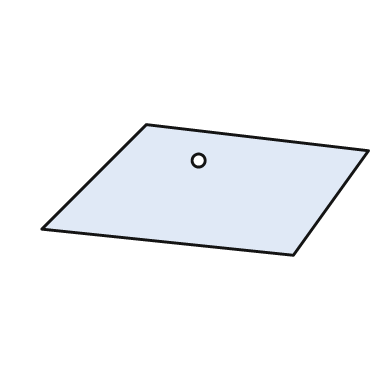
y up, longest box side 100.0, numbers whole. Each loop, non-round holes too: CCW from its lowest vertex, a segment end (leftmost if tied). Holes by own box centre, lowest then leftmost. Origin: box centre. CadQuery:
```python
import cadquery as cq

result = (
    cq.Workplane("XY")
    .moveTo(27.0, -20.0)
    .lineTo(50.0, 12.0)
    .lineTo(-18.0, 20.0)
    .lineTo(-50.0, -12.0)
    .close()
    .moveTo(-2.0, 9.0)
    .circle(2.0)
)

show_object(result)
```